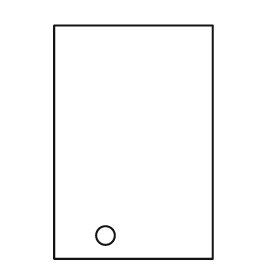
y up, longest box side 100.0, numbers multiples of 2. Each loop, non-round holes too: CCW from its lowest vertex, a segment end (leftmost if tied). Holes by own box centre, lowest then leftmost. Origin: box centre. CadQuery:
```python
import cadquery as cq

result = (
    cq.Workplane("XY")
    .moveTo(-34.0, -50.0)
    .lineTo(34.0, -50.0)
    .lineTo(34.0, 50.0)
    .lineTo(-34.0, 50.0)
    .close()
    .moveTo(-12.0, -40.0)
    .circle(4.0)
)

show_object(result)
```